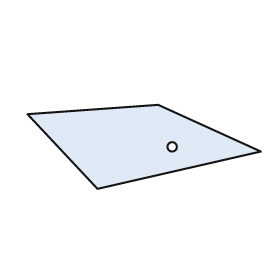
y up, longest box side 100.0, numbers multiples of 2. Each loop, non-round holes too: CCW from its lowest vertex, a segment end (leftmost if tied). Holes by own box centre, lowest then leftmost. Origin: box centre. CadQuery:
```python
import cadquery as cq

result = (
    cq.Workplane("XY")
    .moveTo(-20.0, -18.0)
    .lineTo(50.0, -2.0)
    .lineTo(6.0, 18.0)
    .lineTo(-50.0, 14.0)
    .close()
    .moveTo(12.0, 0.0)
    .circle(2.0)
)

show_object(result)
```